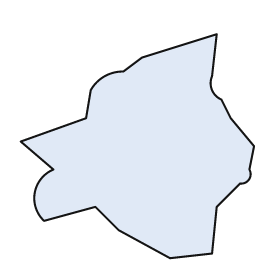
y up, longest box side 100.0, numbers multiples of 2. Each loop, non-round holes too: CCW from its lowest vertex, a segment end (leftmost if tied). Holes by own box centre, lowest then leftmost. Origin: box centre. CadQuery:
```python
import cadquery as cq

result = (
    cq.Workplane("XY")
    .moveTo(14.0, -48.0)
    .lineTo(32.0, -46.0)
    .lineTo(34.0, -26.0)
    .lineTo(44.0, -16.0)
    .threePointArc((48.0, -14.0), (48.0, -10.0))
    .lineTo(50.0, 0.0)
    .lineTo(40.0, 12.0)
    .lineTo(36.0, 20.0)
    .threePointArc((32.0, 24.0), (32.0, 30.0))
    .lineTo(34.0, 48.0)
    .lineTo(2.0, 38.0)
    .lineTo(-6.0, 32.0)
    .threePointArc((-14.0, 30.0), (-20.0, 24.0))
    .lineTo(-22.0, 12.0)
    .lineTo(-50.0, 2.0)
    .lineTo(-36.0, -10.0)
    .threePointArc((-44.0, -20.0), (-40.0, -32.0))
    .lineTo(-18.0, -26.0)
    .lineTo(-8.0, -36.0)
    .close()
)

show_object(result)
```